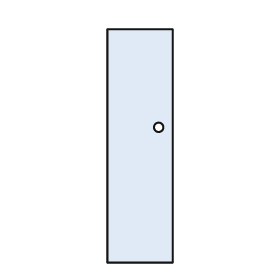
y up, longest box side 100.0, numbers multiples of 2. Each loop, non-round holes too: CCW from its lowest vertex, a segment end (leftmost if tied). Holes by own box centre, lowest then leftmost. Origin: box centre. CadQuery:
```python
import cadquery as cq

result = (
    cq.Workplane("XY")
    .moveTo(-14.0, -50.0)
    .lineTo(14.0, -50.0)
    .lineTo(14.0, 50.0)
    .lineTo(-14.0, 50.0)
    .close()
    .moveTo(8.0, 8.0)
    .circle(2.0)
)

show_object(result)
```